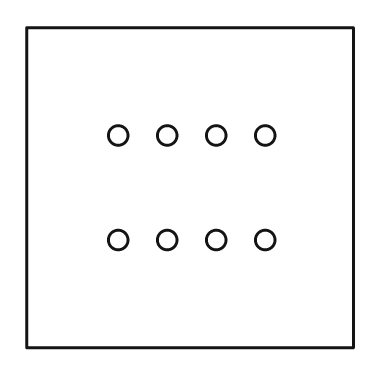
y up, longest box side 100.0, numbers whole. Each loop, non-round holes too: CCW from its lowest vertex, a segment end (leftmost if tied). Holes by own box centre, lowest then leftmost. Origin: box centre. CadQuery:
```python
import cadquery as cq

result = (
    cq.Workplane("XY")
    .moveTo(-50.0, -49.0)
    .lineTo(50.0, -49.0)
    .lineTo(50.0, 49.0)
    .lineTo(-50.0, 49.0)
    .close()
    .moveTo(-22.0, -16.0)
    .circle(3.0)
    .moveTo(-7.0, -16.0)
    .circle(3.0)
    .moveTo(8.0, -16.0)
    .circle(3.0)
    .moveTo(23.0, -16.0)
    .circle(3.0)
    .moveTo(-22.0, 16.0)
    .circle(3.0)
    .moveTo(-7.0, 16.0)
    .circle(3.0)
    .moveTo(8.0, 16.0)
    .circle(3.0)
    .moveTo(23.0, 16.0)
    .circle(3.0)
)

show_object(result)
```